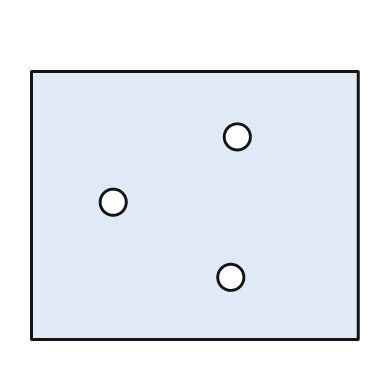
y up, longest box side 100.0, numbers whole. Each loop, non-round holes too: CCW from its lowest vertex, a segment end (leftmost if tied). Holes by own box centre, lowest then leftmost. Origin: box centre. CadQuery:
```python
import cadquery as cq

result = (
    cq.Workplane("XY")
    .moveTo(-50.0, -41.0)
    .lineTo(50.0, -41.0)
    .lineTo(50.0, 41.0)
    .lineTo(-50.0, 41.0)
    .close()
    .moveTo(11.0, -22.0)
    .circle(4.0)
    .moveTo(-25.0, 1.0)
    .circle(4.0)
    .moveTo(13.0, 21.0)
    .circle(4.0)
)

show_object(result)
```